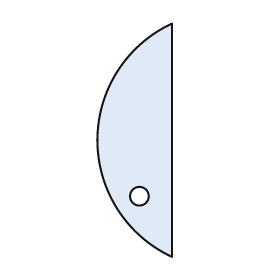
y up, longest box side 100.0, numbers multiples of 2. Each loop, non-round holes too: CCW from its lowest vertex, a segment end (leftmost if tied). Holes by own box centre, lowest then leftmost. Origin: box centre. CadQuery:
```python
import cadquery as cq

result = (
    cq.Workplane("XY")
    .moveTo(16.0, -50.0)
    .lineTo(16.0, 50.0)
    .threePointArc((-16.0, 0.0), (16.0, -50.0))
    .close()
    .moveTo(2.0, -24.0)
    .circle(4.0)
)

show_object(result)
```